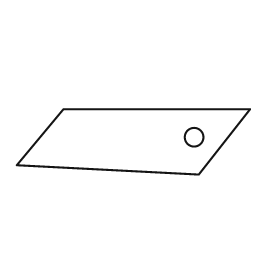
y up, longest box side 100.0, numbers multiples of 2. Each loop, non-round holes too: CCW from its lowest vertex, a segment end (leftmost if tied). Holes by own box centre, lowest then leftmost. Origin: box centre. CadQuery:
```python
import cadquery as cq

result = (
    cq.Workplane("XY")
    .moveTo(28.0, -14.0)
    .lineTo(50.0, 14.0)
    .lineTo(-30.0, 14.0)
    .lineTo(-50.0, -10.0)
    .close()
    .moveTo(26.0, 2.0)
    .circle(4.0)
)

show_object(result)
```